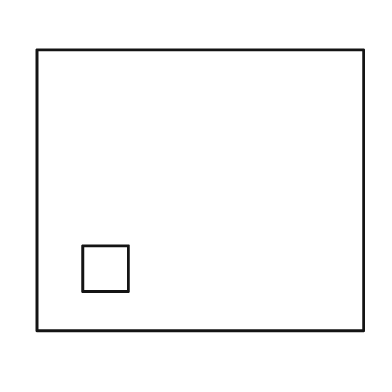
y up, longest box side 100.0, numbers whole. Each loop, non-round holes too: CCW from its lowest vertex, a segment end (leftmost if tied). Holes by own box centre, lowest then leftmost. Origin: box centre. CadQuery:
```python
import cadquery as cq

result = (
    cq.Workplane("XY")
    .moveTo(-50.0, -43.0)
    .lineTo(50.0, -43.0)
    .lineTo(50.0, 43.0)
    .lineTo(-50.0, 43.0)
    .close()
    .moveTo(-36.0, -31.0)
    .lineTo(-22.0, -31.0)
    .lineTo(-22.0, -17.0)
    .lineTo(-36.0, -17.0)
    .close()
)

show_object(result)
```